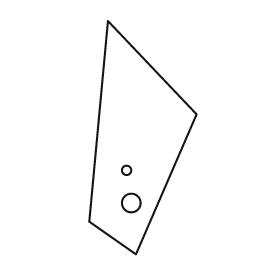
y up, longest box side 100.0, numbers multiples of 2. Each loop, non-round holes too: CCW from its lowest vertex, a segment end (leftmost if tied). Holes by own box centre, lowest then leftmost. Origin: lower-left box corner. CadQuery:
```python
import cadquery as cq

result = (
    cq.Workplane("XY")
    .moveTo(20.0, 0.0)
    .lineTo(46.0, 60.0)
    .lineTo(8.0, 100.0)
    .lineTo(0.0, 14.0)
    .close()
    .moveTo(18.0, 22.0)
    .circle(4.0)
    .moveTo(16.0, 36.0)
    .circle(2.0)
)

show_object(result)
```